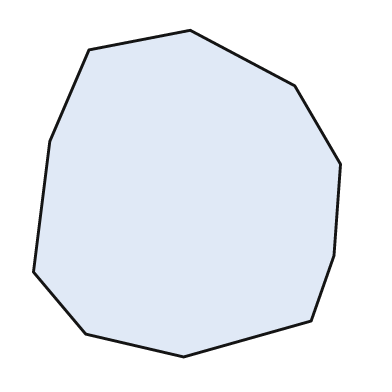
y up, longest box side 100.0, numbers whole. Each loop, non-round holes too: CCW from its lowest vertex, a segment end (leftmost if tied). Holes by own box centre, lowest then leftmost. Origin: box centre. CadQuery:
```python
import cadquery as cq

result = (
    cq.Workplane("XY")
    .moveTo(-1.0, -50.0)
    .lineTo(38.0, -39.0)
    .lineTo(45.0, -19.0)
    .lineTo(47.0, 9.0)
    .lineTo(33.0, 33.0)
    .lineTo(1.0, 50.0)
    .lineTo(-30.0, 44.0)
    .lineTo(-42.0, 16.0)
    .lineTo(-47.0, -24.0)
    .lineTo(-31.0, -43.0)
    .close()
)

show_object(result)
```